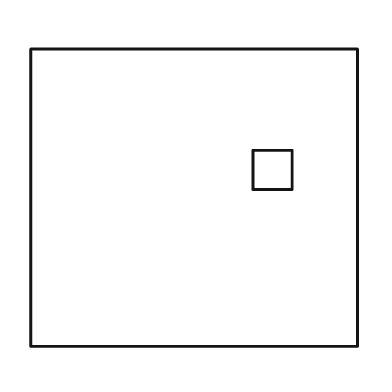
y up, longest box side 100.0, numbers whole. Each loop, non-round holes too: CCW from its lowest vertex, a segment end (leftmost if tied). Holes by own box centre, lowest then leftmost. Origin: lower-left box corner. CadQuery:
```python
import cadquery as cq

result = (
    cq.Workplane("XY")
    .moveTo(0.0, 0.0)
    .lineTo(100.0, 0.0)
    .lineTo(100.0, 91.0)
    .lineTo(0.0, 91.0)
    .close()
    .moveTo(68.0, 48.0)
    .lineTo(80.0, 48.0)
    .lineTo(80.0, 60.0)
    .lineTo(68.0, 60.0)
    .close()
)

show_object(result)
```